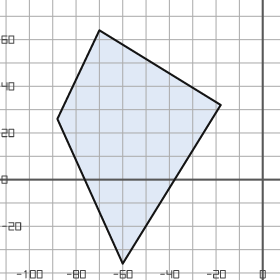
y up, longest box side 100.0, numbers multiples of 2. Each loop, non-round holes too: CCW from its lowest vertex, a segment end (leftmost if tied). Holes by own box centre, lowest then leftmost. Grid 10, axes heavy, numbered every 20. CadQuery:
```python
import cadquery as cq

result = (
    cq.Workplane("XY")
    .moveTo(-60.0, -36.0)
    .lineTo(-18.0, 32.0)
    .lineTo(-70.0, 64.0)
    .lineTo(-88.0, 26.0)
    .close()
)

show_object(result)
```